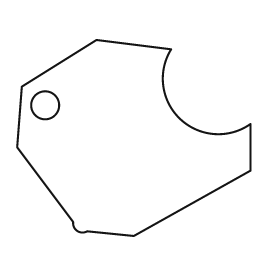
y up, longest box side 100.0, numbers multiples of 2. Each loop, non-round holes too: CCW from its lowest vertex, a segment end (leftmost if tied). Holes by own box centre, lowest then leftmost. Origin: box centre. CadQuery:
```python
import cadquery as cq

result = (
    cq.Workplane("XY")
    .moveTo(0.0, -42.0)
    .lineTo(50.0, -14.0)
    .lineTo(50.0, 6.0)
    .threePointArc((20.0, 8.0), (16.0, 38.0))
    .lineTo(-16.0, 42.0)
    .lineTo(-48.0, 22.0)
    .lineTo(-50.0, -4.0)
    .lineTo(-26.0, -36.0)
    .threePointArc((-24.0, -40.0), (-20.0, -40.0))
    .close()
    .moveTo(-38.0, 14.0)
    .circle(6.0)
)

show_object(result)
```